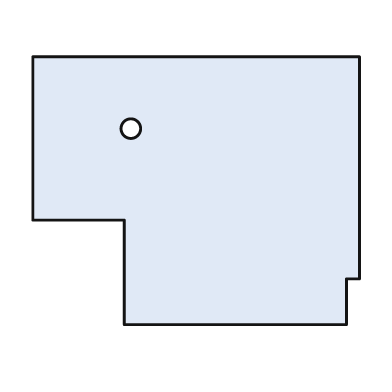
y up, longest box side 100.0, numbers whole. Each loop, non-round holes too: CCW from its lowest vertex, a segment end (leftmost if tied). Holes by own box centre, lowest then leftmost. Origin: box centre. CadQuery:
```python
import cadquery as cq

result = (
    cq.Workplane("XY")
    .moveTo(-22.0, -41.0)
    .lineTo(46.0, -41.0)
    .lineTo(46.0, -27.0)
    .lineTo(50.0, -27.0)
    .lineTo(50.0, 41.0)
    .lineTo(-50.0, 41.0)
    .lineTo(-50.0, -9.0)
    .lineTo(-22.0, -9.0)
    .close()
    .moveTo(-20.0, 19.0)
    .circle(3.0)
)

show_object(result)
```